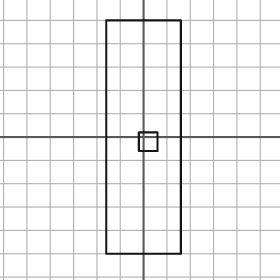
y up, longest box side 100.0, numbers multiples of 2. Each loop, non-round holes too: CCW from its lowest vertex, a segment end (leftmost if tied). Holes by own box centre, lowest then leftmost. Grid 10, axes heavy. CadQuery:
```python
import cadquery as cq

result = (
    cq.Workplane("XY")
    .moveTo(-16.0, -50.0)
    .lineTo(16.0, -50.0)
    .lineTo(16.0, 50.0)
    .lineTo(-16.0, 50.0)
    .close()
    .moveTo(-2.0, -6.0)
    .lineTo(6.0, -6.0)
    .lineTo(6.0, 2.0)
    .lineTo(-2.0, 2.0)
    .close()
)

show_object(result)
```